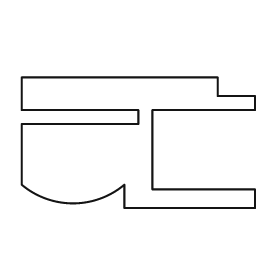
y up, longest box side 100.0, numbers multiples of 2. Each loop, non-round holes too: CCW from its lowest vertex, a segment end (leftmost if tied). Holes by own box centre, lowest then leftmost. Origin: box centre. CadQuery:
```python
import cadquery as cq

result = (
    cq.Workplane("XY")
    .moveTo(-6.0, -28.0)
    .lineTo(50.0, -28.0)
    .lineTo(50.0, -20.0)
    .lineTo(6.0, -20.0)
    .lineTo(6.0, 14.0)
    .lineTo(50.0, 14.0)
    .lineTo(50.0, 20.0)
    .lineTo(34.0, 20.0)
    .lineTo(34.0, 28.0)
    .lineTo(-50.0, 28.0)
    .lineTo(-50.0, 14.0)
    .lineTo(0.0, 14.0)
    .lineTo(0.0, 8.0)
    .lineTo(-50.0, 8.0)
    .lineTo(-50.0, -18.0)
    .threePointArc((-28.0, -26.0), (-6.0, -18.0))
    .close()
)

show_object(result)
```